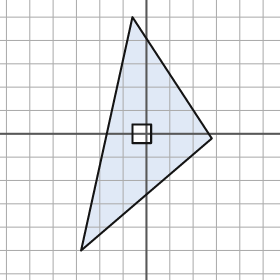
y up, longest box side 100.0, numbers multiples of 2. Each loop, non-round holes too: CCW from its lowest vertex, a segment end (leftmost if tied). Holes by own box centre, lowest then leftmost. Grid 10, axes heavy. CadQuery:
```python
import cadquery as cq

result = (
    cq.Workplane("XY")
    .moveTo(-28.0, -50.0)
    .lineTo(28.0, -2.0)
    .lineTo(-6.0, 50.0)
    .close()
    .moveTo(-6.0, -4.0)
    .lineTo(2.0, -4.0)
    .lineTo(2.0, 4.0)
    .lineTo(-6.0, 4.0)
    .close()
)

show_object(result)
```